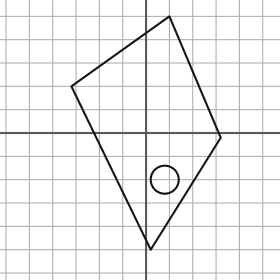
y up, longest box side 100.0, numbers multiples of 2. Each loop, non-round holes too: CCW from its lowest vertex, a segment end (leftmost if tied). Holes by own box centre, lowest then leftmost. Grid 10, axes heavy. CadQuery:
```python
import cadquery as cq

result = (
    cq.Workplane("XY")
    .moveTo(2.0, -50.0)
    .lineTo(32.0, -2.0)
    .lineTo(10.0, 50.0)
    .lineTo(-32.0, 20.0)
    .close()
    .moveTo(8.0, -20.0)
    .circle(6.0)
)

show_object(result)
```